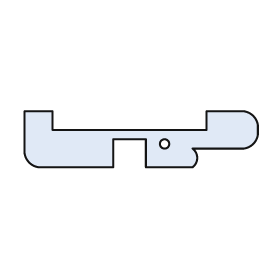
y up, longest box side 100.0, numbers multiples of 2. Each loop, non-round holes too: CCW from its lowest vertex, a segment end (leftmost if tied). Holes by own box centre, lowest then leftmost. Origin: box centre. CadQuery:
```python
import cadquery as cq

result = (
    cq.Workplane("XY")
    .moveTo(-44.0, -12.0)
    .lineTo(-12.0, -12.0)
    .lineTo(-12.0, 0.0)
    .lineTo(2.0, 0.0)
    .lineTo(2.0, -12.0)
    .lineTo(22.0, -12.0)
    .threePointArc((24.0, -8.0), (22.0, -4.0))
    .lineTo(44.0, -4.0)
    .threePointArc((48.0, -2.0), (50.0, 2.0))
    .lineTo(50.0, 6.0)
    .threePointArc((48.0, 10.0), (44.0, 12.0))
    .lineTo(28.0, 12.0)
    .lineTo(28.0, 4.0)
    .lineTo(-38.0, 4.0)
    .lineTo(-38.0, 12.0)
    .lineTo(-50.0, 12.0)
    .lineTo(-50.0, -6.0)
    .threePointArc((-48.0, -10.0), (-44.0, -12.0))
    .close()
    .moveTo(10.0, -2.0)
    .circle(2.0)
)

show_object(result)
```